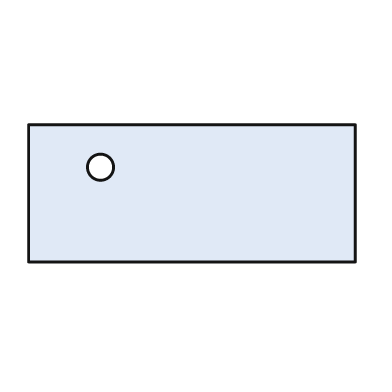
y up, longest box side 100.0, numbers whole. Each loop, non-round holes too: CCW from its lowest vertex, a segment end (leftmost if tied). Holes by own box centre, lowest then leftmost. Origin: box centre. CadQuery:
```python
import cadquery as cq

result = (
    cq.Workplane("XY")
    .moveTo(-50.0, -21.0)
    .lineTo(50.0, -21.0)
    .lineTo(50.0, 21.0)
    .lineTo(-50.0, 21.0)
    .close()
    .moveTo(-28.0, 8.0)
    .circle(4.0)
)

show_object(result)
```